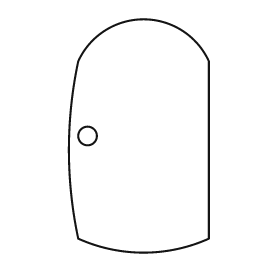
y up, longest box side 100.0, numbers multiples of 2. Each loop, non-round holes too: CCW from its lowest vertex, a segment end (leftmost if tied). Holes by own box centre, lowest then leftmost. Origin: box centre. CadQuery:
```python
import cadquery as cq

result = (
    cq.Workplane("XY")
    .moveTo(-26.0, -44.0)
    .threePointArc((2.0, -50.0), (30.0, -44.0))
    .lineTo(30.0, 32.0)
    .threePointArc((2.0, 50.0), (-26.0, 32.0))
    .threePointArc((-30.0, -6.0), (-26.0, -44.0))
    .close()
    .moveTo(-22.0, 0.0)
    .circle(4.0)
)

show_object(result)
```